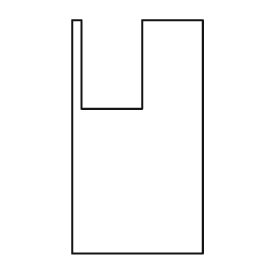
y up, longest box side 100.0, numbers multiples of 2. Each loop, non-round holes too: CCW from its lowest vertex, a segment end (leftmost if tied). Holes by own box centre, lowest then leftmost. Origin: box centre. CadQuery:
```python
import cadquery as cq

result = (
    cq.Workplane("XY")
    .moveTo(-28.0, -50.0)
    .lineTo(28.0, -50.0)
    .lineTo(28.0, 50.0)
    .lineTo(2.0, 50.0)
    .lineTo(2.0, 12.0)
    .lineTo(-24.0, 12.0)
    .lineTo(-24.0, 50.0)
    .lineTo(-28.0, 50.0)
    .close()
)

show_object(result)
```